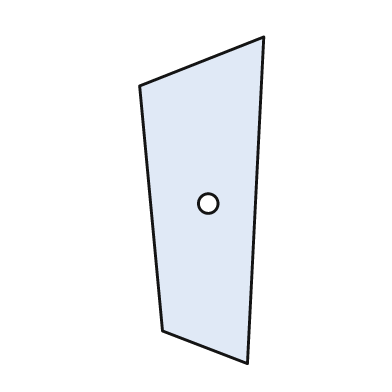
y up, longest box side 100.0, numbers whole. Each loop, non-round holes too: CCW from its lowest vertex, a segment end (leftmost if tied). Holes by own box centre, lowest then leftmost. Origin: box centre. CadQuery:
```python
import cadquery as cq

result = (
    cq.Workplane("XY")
    .moveTo(14.0, -50.0)
    .lineTo(19.0, 50.0)
    .lineTo(-19.0, 35.0)
    .lineTo(-12.0, -40.0)
    .close()
    .moveTo(2.0, -1.0)
    .circle(3.0)
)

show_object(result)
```